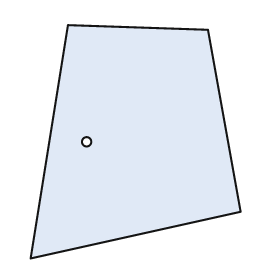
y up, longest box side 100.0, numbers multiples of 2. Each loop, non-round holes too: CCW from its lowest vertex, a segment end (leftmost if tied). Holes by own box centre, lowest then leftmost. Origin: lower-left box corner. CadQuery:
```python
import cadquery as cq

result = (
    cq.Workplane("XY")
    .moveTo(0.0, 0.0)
    .lineTo(90.0, 20.0)
    .lineTo(76.0, 98.0)
    .lineTo(16.0, 100.0)
    .close()
    .moveTo(24.0, 50.0)
    .circle(2.0)
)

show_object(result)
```